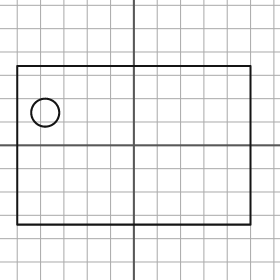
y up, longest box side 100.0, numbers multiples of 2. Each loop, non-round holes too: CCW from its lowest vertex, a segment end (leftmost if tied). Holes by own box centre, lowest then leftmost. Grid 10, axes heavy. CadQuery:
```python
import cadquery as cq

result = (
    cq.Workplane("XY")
    .moveTo(-50.0, -34.0)
    .lineTo(50.0, -34.0)
    .lineTo(50.0, 34.0)
    .lineTo(-50.0, 34.0)
    .close()
    .moveTo(-38.0, 14.0)
    .circle(6.0)
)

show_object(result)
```